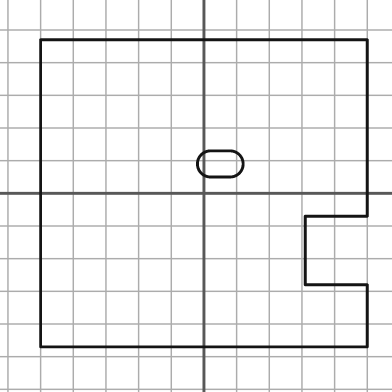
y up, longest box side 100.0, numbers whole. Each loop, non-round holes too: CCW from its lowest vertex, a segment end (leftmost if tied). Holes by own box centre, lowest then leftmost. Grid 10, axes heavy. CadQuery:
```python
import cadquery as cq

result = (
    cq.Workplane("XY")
    .moveTo(-50.0, -47.0)
    .lineTo(50.0, -47.0)
    .lineTo(50.0, -28.0)
    .lineTo(31.0, -28.0)
    .lineTo(31.0, -7.0)
    .lineTo(50.0, -7.0)
    .lineTo(50.0, 47.0)
    .lineTo(-50.0, 47.0)
    .close()
    .moveTo(2.0, 5.0)
    .lineTo(8.0, 5.0)
    .threePointArc((12.0, 9.0), (8.0, 13.0))
    .lineTo(2.0, 13.0)
    .threePointArc((-2.0, 9.0), (2.0, 5.0))
    .close()
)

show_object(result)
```